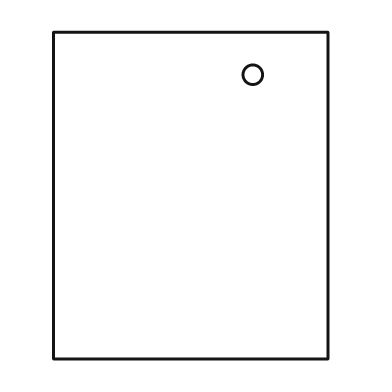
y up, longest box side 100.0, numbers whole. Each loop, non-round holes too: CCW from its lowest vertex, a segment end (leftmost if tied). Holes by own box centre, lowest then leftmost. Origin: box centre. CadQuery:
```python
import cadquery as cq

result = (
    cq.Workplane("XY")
    .moveTo(-42.0, -50.0)
    .lineTo(42.0, -50.0)
    .lineTo(42.0, 50.0)
    .lineTo(-42.0, 50.0)
    .close()
    .moveTo(19.0, 37.0)
    .circle(3.0)
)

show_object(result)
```